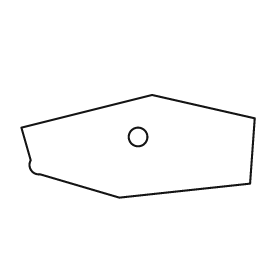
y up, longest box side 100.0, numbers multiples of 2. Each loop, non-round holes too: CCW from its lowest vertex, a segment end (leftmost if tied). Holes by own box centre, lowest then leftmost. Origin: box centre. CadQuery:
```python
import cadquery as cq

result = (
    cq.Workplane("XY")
    .moveTo(-8.0, -22.0)
    .lineTo(48.0, -16.0)
    .lineTo(50.0, 12.0)
    .lineTo(6.0, 22.0)
    .lineTo(-50.0, 8.0)
    .lineTo(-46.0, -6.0)
    .threePointArc((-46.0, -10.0), (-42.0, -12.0))
    .close()
    .moveTo(0.0, 4.0)
    .circle(4.0)
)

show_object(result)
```